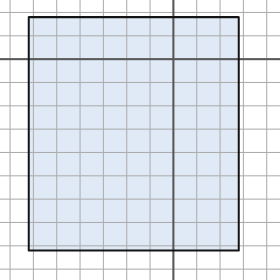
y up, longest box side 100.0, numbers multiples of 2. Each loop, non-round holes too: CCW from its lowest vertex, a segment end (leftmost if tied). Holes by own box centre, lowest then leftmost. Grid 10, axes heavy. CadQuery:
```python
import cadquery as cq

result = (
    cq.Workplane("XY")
    .moveTo(-62.0, -82.0)
    .lineTo(28.0, -82.0)
    .lineTo(28.0, 18.0)
    .lineTo(-62.0, 18.0)
    .close()
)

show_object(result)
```